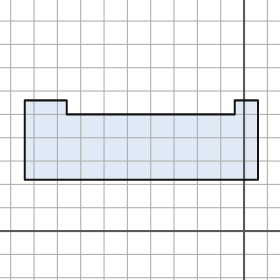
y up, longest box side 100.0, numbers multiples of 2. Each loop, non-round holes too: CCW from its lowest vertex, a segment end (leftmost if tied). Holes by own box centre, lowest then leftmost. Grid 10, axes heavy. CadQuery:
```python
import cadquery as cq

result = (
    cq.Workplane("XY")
    .moveTo(-94.0, 22.0)
    .lineTo(6.0, 22.0)
    .lineTo(6.0, 56.0)
    .lineTo(-4.0, 56.0)
    .lineTo(-4.0, 50.0)
    .lineTo(-76.0, 50.0)
    .lineTo(-76.0, 56.0)
    .lineTo(-94.0, 56.0)
    .close()
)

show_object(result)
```